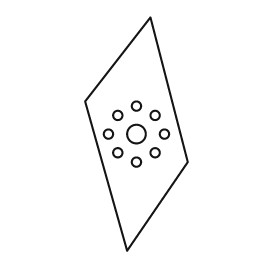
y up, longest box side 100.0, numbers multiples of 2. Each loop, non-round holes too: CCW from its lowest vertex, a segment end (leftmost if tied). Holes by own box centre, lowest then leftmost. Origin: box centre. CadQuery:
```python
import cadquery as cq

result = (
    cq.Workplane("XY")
    .moveTo(-4.0, -50.0)
    .lineTo(22.0, -12.0)
    .lineTo(6.0, 50.0)
    .lineTo(-22.0, 14.0)
    .close()
    .moveTo(0.0, -12.0)
    .circle(2.0)
    .moveTo(-8.0, -8.0)
    .circle(2.0)
    .moveTo(8.0, -8.0)
    .circle(2.0)
    .moveTo(-12.0, 0.0)
    .circle(2.0)
    .moveTo(0.0, 0.0)
    .circle(4.0)
    .moveTo(12.0, 0.0)
    .circle(2.0)
    .moveTo(-8.0, 8.0)
    .circle(2.0)
    .moveTo(8.0, 8.0)
    .circle(2.0)
    .moveTo(0.0, 12.0)
    .circle(2.0)
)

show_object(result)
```